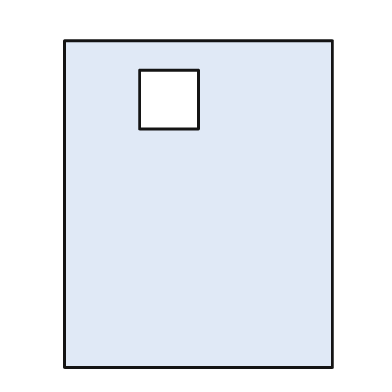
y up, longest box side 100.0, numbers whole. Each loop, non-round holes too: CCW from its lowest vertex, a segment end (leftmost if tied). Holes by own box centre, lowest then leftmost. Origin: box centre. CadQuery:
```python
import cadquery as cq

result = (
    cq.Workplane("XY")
    .moveTo(-41.0, -50.0)
    .lineTo(41.0, -50.0)
    .lineTo(41.0, 50.0)
    .lineTo(-41.0, 50.0)
    .close()
    .moveTo(-18.0, 23.0)
    .lineTo(0.0, 23.0)
    .lineTo(0.0, 41.0)
    .lineTo(-18.0, 41.0)
    .close()
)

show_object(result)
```